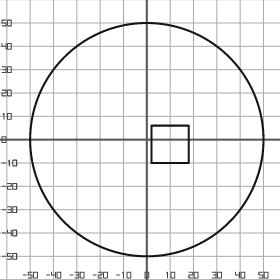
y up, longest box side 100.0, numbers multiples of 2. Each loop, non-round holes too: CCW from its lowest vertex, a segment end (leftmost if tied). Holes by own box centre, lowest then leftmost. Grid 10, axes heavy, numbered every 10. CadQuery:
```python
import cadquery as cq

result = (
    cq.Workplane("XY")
    .moveTo(0.0, 0.0)
    .circle(50.0)
    .moveTo(2.0, -10.0)
    .lineTo(18.0, -10.0)
    .lineTo(18.0, 6.0)
    .lineTo(2.0, 6.0)
    .close()
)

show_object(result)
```